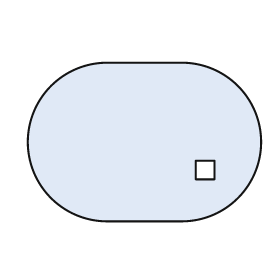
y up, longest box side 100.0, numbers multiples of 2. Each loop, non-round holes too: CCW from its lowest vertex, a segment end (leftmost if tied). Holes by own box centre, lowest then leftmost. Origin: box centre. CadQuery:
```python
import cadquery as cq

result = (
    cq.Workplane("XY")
    .moveTo(-16.0, -34.0)
    .lineTo(16.0, -34.0)
    .threePointArc((50.0, 0.0), (16.0, 34.0))
    .lineTo(-16.0, 34.0)
    .threePointArc((-50.0, 0.0), (-16.0, -34.0))
    .close()
    .moveTo(22.0, -16.0)
    .lineTo(30.0, -16.0)
    .lineTo(30.0, -8.0)
    .lineTo(22.0, -8.0)
    .close()
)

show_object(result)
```